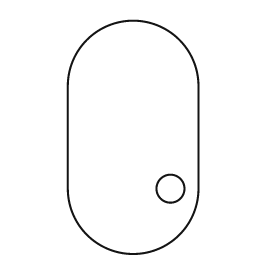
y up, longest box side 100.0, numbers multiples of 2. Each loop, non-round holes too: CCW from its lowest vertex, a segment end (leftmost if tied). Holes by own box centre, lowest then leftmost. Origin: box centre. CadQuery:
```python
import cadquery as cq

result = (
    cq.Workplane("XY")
    .moveTo(-28.0, -22.0)
    .threePointArc((0.0, -50.0), (28.0, -22.0))
    .lineTo(28.0, 22.0)
    .threePointArc((0.0, 50.0), (-28.0, 22.0))
    .close()
    .moveTo(16.0, -22.0)
    .circle(6.0)
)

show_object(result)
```